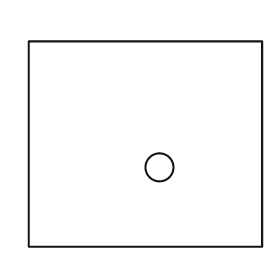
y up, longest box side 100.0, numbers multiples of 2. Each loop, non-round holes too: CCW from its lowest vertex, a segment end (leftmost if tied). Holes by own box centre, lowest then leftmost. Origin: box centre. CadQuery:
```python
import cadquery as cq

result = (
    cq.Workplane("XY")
    .moveTo(-50.0, -44.0)
    .lineTo(50.0, -44.0)
    .lineTo(50.0, 44.0)
    .lineTo(-50.0, 44.0)
    .close()
    .moveTo(6.0, -10.0)
    .circle(6.0)
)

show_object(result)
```